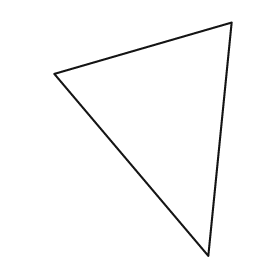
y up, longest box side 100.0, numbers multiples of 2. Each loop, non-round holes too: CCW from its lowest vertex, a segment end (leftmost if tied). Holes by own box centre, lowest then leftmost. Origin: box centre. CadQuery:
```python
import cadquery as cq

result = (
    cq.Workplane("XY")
    .moveTo(28.0, -50.0)
    .lineTo(38.0, 50.0)
    .lineTo(-38.0, 28.0)
    .close()
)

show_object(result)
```